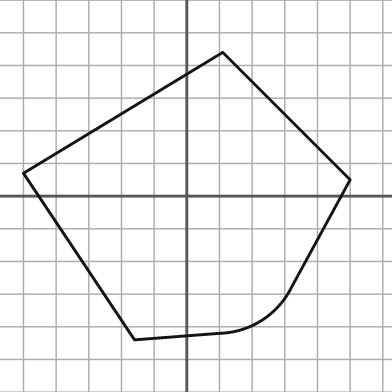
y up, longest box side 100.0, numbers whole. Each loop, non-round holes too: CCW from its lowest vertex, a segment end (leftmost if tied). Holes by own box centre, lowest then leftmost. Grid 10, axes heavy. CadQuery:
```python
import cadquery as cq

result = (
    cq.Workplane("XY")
    .moveTo(-16.0, -44.0)
    .lineTo(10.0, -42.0)
    .threePointArc((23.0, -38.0), (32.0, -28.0))
    .lineTo(50.0, 5.0)
    .lineTo(11.0, 44.0)
    .lineTo(-50.0, 7.0)
    .close()
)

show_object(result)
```